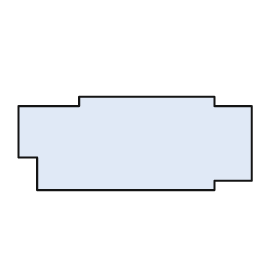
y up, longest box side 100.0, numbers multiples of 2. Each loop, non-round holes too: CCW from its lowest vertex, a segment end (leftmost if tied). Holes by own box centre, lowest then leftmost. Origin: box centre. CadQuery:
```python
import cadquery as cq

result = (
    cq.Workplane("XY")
    .moveTo(-42.0, -20.0)
    .lineTo(34.0, -20.0)
    .lineTo(34.0, -16.0)
    .lineTo(50.0, -16.0)
    .lineTo(50.0, 16.0)
    .lineTo(34.0, 16.0)
    .lineTo(34.0, 20.0)
    .lineTo(-24.0, 20.0)
    .lineTo(-24.0, 16.0)
    .lineTo(-50.0, 16.0)
    .lineTo(-50.0, -6.0)
    .lineTo(-42.0, -6.0)
    .close()
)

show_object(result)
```